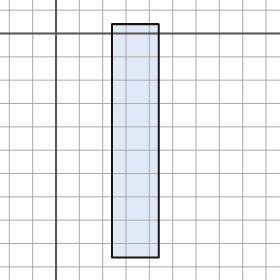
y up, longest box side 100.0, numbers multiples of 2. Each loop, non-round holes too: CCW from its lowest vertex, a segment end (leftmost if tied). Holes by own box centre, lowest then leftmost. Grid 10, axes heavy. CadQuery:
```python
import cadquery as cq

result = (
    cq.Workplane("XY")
    .moveTo(24.0, -96.0)
    .lineTo(44.0, -96.0)
    .lineTo(44.0, 4.0)
    .lineTo(24.0, 4.0)
    .close()
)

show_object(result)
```